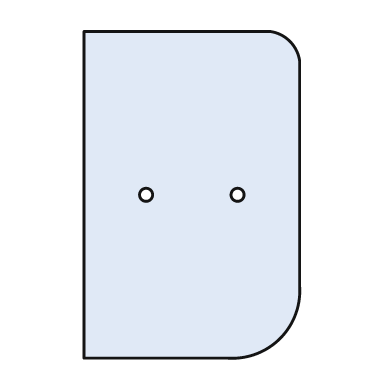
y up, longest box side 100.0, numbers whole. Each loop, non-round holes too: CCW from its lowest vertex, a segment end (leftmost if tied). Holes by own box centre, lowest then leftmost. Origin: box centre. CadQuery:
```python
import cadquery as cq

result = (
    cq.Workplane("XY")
    .moveTo(-33.0, -50.0)
    .lineTo(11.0, -50.0)
    .threePointArc((27.0, -44.0), (33.0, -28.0))
    .lineTo(33.0, 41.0)
    .threePointArc((30.0, 47.0), (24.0, 50.0))
    .lineTo(-33.0, 50.0)
    .close()
    .moveTo(-14.0, 0.0)
    .circle(2.0)
    .moveTo(14.0, 0.0)
    .circle(2.0)
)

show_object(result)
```